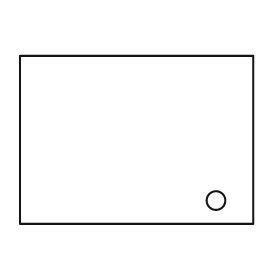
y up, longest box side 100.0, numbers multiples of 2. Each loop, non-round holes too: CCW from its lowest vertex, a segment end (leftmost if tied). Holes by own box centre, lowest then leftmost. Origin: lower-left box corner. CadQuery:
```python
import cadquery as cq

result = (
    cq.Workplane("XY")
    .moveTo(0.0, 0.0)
    .lineTo(100.0, 0.0)
    .lineTo(100.0, 72.0)
    .lineTo(0.0, 72.0)
    .close()
    .moveTo(84.0, 10.0)
    .circle(4.0)
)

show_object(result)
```